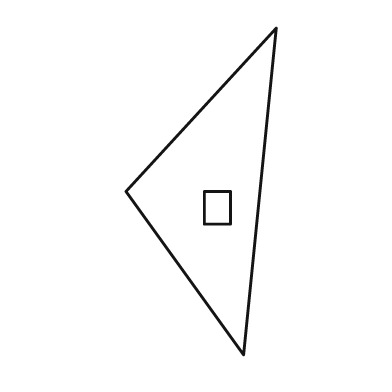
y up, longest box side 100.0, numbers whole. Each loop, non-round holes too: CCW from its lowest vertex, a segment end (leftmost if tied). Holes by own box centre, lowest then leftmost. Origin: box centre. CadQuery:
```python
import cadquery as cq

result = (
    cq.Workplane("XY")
    .moveTo(13.0, -50.0)
    .lineTo(23.0, 50.0)
    .lineTo(-23.0, 0.0)
    .close()
    .moveTo(1.0, -10.0)
    .lineTo(9.0, -10.0)
    .lineTo(9.0, 0.0)
    .lineTo(1.0, 0.0)
    .close()
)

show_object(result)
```